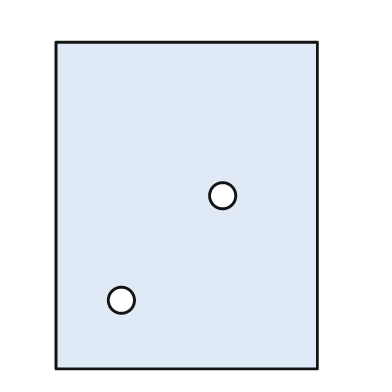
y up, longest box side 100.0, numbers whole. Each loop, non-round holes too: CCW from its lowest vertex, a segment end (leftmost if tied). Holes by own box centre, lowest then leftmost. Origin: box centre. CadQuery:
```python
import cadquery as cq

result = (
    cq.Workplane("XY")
    .moveTo(-40.0, -50.0)
    .lineTo(40.0, -50.0)
    .lineTo(40.0, 50.0)
    .lineTo(-40.0, 50.0)
    .close()
    .moveTo(-20.0, -29.0)
    .circle(4.0)
    .moveTo(11.0, 3.0)
    .circle(4.0)
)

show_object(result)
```